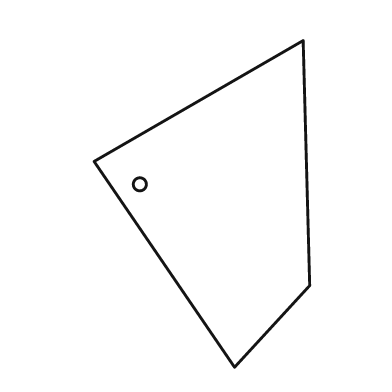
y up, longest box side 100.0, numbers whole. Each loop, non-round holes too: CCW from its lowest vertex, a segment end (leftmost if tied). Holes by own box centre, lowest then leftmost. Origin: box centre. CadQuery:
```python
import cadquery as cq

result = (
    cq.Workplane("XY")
    .moveTo(10.0, -50.0)
    .lineTo(33.0, -25.0)
    .lineTo(31.0, 50.0)
    .lineTo(-33.0, 13.0)
    .close()
    .moveTo(-19.0, 6.0)
    .circle(2.0)
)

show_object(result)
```